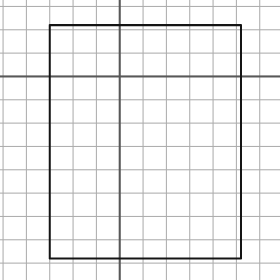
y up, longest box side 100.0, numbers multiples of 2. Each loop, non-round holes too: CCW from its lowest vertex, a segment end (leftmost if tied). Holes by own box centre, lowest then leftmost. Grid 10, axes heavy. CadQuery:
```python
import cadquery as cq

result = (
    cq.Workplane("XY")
    .moveTo(-30.0, -78.0)
    .lineTo(52.0, -78.0)
    .lineTo(52.0, 22.0)
    .lineTo(-30.0, 22.0)
    .close()
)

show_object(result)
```